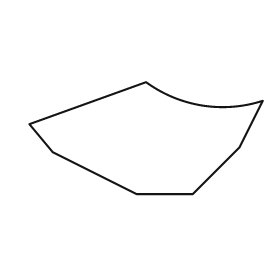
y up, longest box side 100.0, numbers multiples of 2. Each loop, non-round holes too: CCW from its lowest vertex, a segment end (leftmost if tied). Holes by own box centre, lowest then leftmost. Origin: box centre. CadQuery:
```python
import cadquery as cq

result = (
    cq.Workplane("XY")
    .moveTo(-4.0, -24.0)
    .lineTo(20.0, -24.0)
    .lineTo(40.0, -4.0)
    .lineTo(50.0, 16.0)
    .threePointArc((24.0, 14.0), (0.0, 24.0))
    .lineTo(-50.0, 6.0)
    .lineTo(-40.0, -6.0)
    .close()
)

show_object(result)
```